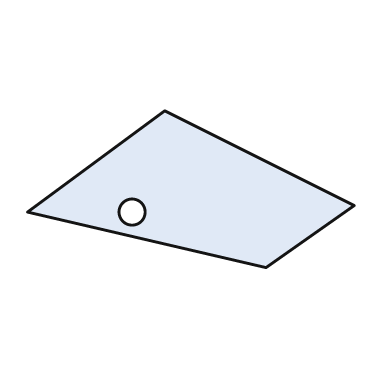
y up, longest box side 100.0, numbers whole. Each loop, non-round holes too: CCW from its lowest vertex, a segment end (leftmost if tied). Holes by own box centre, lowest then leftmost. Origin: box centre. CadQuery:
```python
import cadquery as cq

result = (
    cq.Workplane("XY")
    .moveTo(23.0, -24.0)
    .lineTo(50.0, -5.0)
    .lineTo(-8.0, 24.0)
    .lineTo(-50.0, -7.0)
    .close()
    .moveTo(-18.0, -7.0)
    .circle(4.0)
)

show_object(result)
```